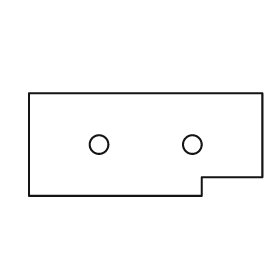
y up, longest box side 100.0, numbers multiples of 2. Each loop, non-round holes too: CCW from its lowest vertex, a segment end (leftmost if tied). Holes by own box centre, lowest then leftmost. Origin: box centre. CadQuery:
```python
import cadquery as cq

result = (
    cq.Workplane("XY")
    .moveTo(-50.0, -22.0)
    .lineTo(24.0, -22.0)
    .lineTo(24.0, -14.0)
    .lineTo(50.0, -14.0)
    .lineTo(50.0, 22.0)
    .lineTo(-50.0, 22.0)
    .close()
    .moveTo(-20.0, 0.0)
    .circle(4.0)
    .moveTo(20.0, 0.0)
    .circle(4.0)
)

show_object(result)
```